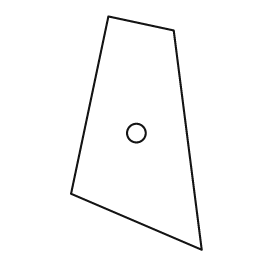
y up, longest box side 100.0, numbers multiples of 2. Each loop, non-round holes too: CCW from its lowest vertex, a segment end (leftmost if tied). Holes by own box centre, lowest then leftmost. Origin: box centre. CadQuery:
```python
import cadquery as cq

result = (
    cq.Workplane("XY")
    .moveTo(28.0, -50.0)
    .lineTo(16.0, 44.0)
    .lineTo(-12.0, 50.0)
    .lineTo(-28.0, -26.0)
    .close()
    .moveTo(0.0, 0.0)
    .circle(4.0)
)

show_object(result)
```